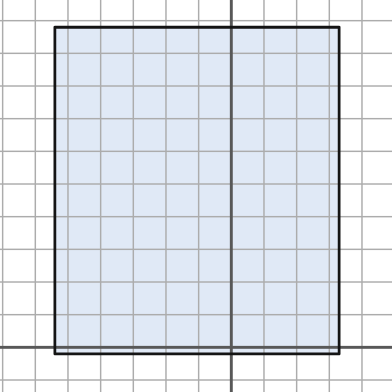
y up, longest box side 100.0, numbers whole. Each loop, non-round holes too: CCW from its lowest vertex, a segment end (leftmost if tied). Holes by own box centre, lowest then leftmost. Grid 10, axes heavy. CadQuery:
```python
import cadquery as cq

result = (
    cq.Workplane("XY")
    .moveTo(-54.0, -2.0)
    .lineTo(33.0, -2.0)
    .lineTo(33.0, 98.0)
    .lineTo(-54.0, 98.0)
    .close()
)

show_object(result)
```